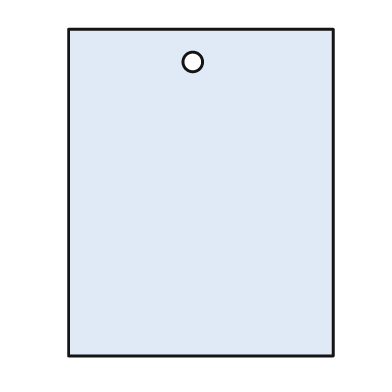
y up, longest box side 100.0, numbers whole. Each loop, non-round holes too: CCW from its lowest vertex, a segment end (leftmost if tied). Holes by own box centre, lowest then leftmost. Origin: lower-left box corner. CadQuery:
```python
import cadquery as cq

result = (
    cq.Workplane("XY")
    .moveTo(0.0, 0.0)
    .lineTo(81.0, 0.0)
    .lineTo(81.0, 100.0)
    .lineTo(0.0, 100.0)
    .close()
    .moveTo(38.0, 90.0)
    .circle(3.0)
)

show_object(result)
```